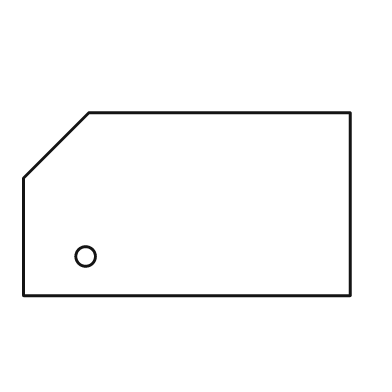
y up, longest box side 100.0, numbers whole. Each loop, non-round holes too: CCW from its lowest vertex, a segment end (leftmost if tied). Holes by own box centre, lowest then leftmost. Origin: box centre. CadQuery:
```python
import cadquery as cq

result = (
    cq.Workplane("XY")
    .moveTo(-50.0, -28.0)
    .lineTo(50.0, -28.0)
    .lineTo(50.0, 28.0)
    .lineTo(-30.0, 28.0)
    .lineTo(-50.0, 8.0)
    .close()
    .moveTo(-31.0, -16.0)
    .circle(3.0)
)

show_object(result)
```